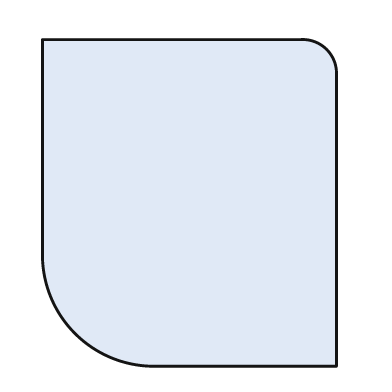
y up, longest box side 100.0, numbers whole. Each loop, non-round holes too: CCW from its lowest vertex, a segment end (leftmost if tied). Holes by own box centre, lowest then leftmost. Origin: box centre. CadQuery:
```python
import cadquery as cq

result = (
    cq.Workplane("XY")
    .moveTo(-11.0, -50.0)
    .lineTo(45.0, -50.0)
    .lineTo(45.0, 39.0)
    .threePointArc((42.0, 47.0), (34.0, 50.0))
    .lineTo(-45.0, 50.0)
    .lineTo(-45.0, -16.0)
    .threePointArc((-35.0, -40.0), (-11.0, -50.0))
    .close()
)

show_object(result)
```